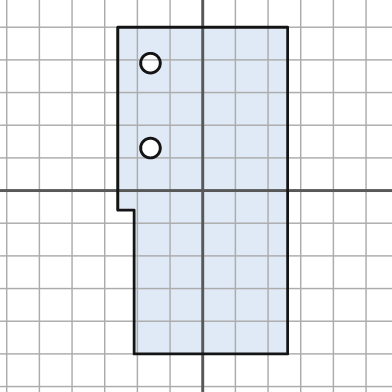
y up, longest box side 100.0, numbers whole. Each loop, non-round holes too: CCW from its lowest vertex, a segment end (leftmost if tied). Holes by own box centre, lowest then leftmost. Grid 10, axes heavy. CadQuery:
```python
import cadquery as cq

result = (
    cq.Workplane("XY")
    .moveTo(-21.0, -50.0)
    .lineTo(26.0, -50.0)
    .lineTo(26.0, 50.0)
    .lineTo(-26.0, 50.0)
    .lineTo(-26.0, -6.0)
    .lineTo(-21.0, -6.0)
    .close()
    .moveTo(-16.0, 13.0)
    .circle(3.0)
    .moveTo(-16.0, 39.0)
    .circle(3.0)
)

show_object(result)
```